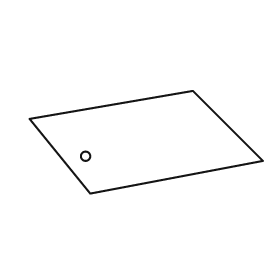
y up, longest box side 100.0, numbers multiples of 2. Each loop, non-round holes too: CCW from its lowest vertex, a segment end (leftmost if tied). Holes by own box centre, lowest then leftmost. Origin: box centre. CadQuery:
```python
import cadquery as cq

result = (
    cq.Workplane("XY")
    .moveTo(-24.0, -22.0)
    .lineTo(50.0, -8.0)
    .lineTo(20.0, 22.0)
    .lineTo(-50.0, 10.0)
    .close()
    .moveTo(-26.0, -6.0)
    .circle(2.0)
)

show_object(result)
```